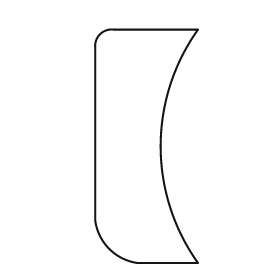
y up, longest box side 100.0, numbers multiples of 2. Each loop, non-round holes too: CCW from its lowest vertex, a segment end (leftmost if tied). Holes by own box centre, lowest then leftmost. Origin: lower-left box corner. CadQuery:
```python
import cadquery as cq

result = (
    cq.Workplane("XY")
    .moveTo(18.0, 0.0)
    .lineTo(44.0, 0.0)
    .threePointArc((28.0, 50.0), (44.0, 100.0))
    .lineTo(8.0, 100.0)
    .threePointArc((2.0, 98.0), (0.0, 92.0))
    .lineTo(0.0, 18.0)
    .threePointArc((6.0, 6.0), (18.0, 0.0))
    .close()
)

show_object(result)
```